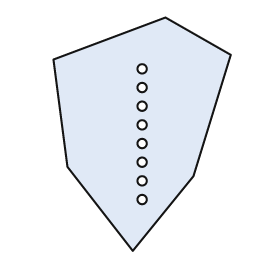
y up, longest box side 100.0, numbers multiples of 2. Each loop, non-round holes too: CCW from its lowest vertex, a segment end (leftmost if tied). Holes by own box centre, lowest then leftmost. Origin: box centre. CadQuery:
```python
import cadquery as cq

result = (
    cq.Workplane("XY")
    .moveTo(-4.0, -50.0)
    .lineTo(22.0, -18.0)
    .lineTo(38.0, 34.0)
    .lineTo(10.0, 50.0)
    .lineTo(-38.0, 32.0)
    .lineTo(-32.0, -14.0)
    .close()
    .moveTo(0.0, -28.0)
    .circle(2.0)
    .moveTo(0.0, -20.0)
    .circle(2.0)
    .moveTo(0.0, -12.0)
    .circle(2.0)
    .moveTo(0.0, -4.0)
    .circle(2.0)
    .moveTo(0.0, 4.0)
    .circle(2.0)
    .moveTo(0.0, 12.0)
    .circle(2.0)
    .moveTo(0.0, 20.0)
    .circle(2.0)
    .moveTo(0.0, 28.0)
    .circle(2.0)
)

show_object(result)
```